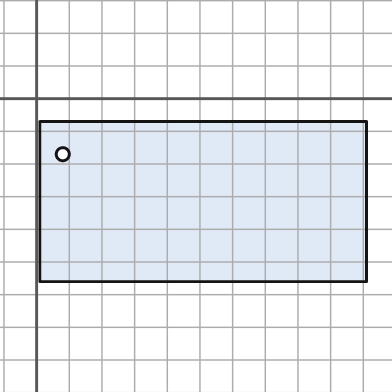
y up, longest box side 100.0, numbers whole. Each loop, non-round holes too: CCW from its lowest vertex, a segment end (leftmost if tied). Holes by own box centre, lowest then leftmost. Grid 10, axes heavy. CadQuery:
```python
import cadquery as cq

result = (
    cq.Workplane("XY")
    .moveTo(1.0, -56.0)
    .lineTo(101.0, -56.0)
    .lineTo(101.0, -7.0)
    .lineTo(1.0, -7.0)
    .close()
    .moveTo(8.0, -17.0)
    .circle(2.0)
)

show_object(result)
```